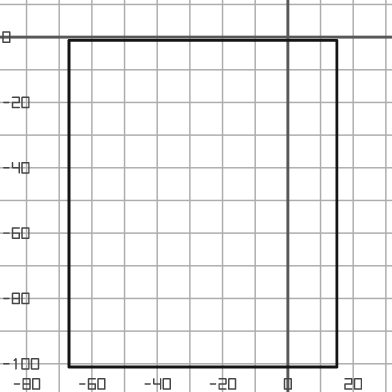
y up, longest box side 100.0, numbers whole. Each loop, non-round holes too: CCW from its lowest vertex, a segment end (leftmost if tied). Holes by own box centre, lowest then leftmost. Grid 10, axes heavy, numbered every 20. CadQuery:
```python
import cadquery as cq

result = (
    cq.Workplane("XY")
    .moveTo(-67.0, -101.0)
    .lineTo(15.0, -101.0)
    .lineTo(15.0, -1.0)
    .lineTo(-67.0, -1.0)
    .close()
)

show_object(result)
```